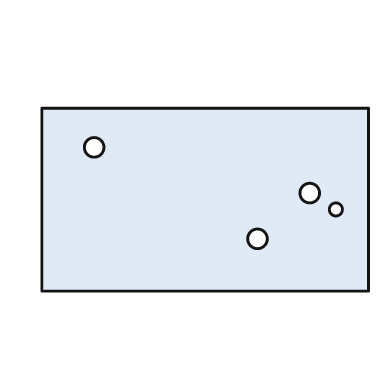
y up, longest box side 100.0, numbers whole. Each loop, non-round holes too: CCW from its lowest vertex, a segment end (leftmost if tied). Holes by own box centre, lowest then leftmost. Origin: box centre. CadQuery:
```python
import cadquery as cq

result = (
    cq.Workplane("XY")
    .moveTo(-50.0, -28.0)
    .lineTo(50.0, -28.0)
    .lineTo(50.0, 28.0)
    .lineTo(-50.0, 28.0)
    .close()
    .moveTo(16.0, -12.0)
    .circle(3.0)
    .moveTo(40.0, -3.0)
    .circle(2.0)
    .moveTo(32.0, 2.0)
    .circle(3.0)
    .moveTo(-34.0, 16.0)
    .circle(3.0)
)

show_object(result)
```